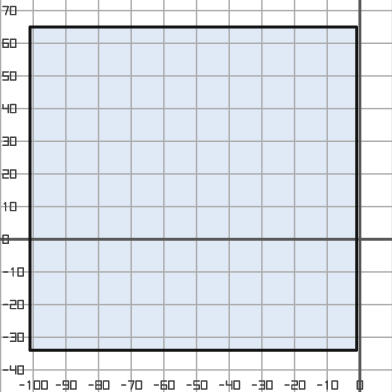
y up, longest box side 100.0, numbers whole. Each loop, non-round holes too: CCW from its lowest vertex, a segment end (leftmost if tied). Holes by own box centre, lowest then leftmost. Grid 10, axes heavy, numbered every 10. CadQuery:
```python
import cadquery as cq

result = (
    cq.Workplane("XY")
    .moveTo(-101.0, -34.0)
    .lineTo(-1.0, -34.0)
    .lineTo(-1.0, 65.0)
    .lineTo(-101.0, 65.0)
    .close()
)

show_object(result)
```